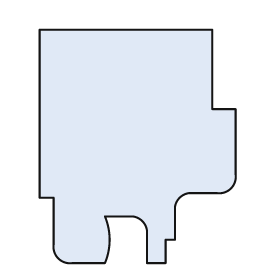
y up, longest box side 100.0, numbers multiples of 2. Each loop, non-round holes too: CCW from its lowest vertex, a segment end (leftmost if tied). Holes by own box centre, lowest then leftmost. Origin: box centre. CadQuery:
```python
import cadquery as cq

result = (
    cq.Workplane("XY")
    .moveTo(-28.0, -50.0)
    .lineTo(-14.0, -50.0)
    .threePointArc((-12.0, -40.0), (-14.0, -30.0))
    .lineTo(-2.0, -30.0)
    .threePointArc((2.0, -32.0), (4.0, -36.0))
    .lineTo(4.0, -50.0)
    .lineTo(12.0, -50.0)
    .lineTo(12.0, -40.0)
    .lineTo(16.0, -40.0)
    .lineTo(16.0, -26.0)
    .threePointArc((18.0, -22.0), (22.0, -20.0))
    .lineTo(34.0, -20.0)
    .threePointArc((40.0, -18.0), (42.0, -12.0))
    .lineTo(42.0, 16.0)
    .lineTo(32.0, 16.0)
    .lineTo(32.0, 50.0)
    .lineTo(-42.0, 50.0)
    .lineTo(-42.0, -22.0)
    .lineTo(-36.0, -22.0)
    .lineTo(-36.0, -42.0)
    .threePointArc((-34.0, -48.0), (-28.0, -50.0))
    .close()
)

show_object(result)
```